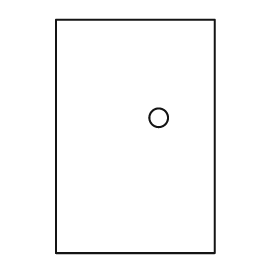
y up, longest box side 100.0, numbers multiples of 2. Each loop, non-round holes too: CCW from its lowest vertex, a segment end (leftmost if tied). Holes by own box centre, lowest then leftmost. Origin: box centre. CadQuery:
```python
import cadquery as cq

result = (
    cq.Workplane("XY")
    .moveTo(-34.0, -50.0)
    .lineTo(34.0, -50.0)
    .lineTo(34.0, 50.0)
    .lineTo(-34.0, 50.0)
    .close()
    .moveTo(10.0, 8.0)
    .circle(4.0)
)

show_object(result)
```